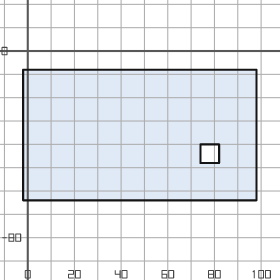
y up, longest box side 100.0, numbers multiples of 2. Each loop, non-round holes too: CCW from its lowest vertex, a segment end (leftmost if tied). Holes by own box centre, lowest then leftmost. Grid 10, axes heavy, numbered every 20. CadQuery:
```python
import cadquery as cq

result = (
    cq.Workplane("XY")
    .moveTo(-2.0, -64.0)
    .lineTo(98.0, -64.0)
    .lineTo(98.0, -8.0)
    .lineTo(-2.0, -8.0)
    .close()
    .moveTo(74.0, -48.0)
    .lineTo(82.0, -48.0)
    .lineTo(82.0, -40.0)
    .lineTo(74.0, -40.0)
    .close()
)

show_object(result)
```